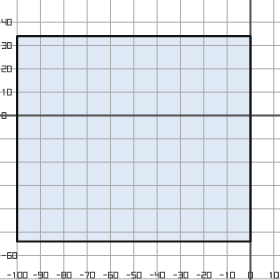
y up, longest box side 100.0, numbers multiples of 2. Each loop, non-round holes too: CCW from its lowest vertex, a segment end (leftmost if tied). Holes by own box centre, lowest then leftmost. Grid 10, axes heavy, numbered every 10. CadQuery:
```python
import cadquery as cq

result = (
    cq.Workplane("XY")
    .moveTo(-100.0, -54.0)
    .lineTo(0.0, -54.0)
    .lineTo(0.0, 34.0)
    .lineTo(-100.0, 34.0)
    .close()
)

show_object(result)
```